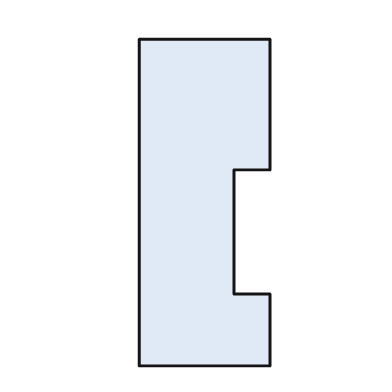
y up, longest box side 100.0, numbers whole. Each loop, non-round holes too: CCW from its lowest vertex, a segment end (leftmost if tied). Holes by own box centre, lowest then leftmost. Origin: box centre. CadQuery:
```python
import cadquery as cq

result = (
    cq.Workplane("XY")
    .moveTo(-20.0, -50.0)
    .lineTo(20.0, -50.0)
    .lineTo(20.0, -28.0)
    .lineTo(9.0, -28.0)
    .lineTo(9.0, 10.0)
    .lineTo(20.0, 10.0)
    .lineTo(20.0, 50.0)
    .lineTo(-20.0, 50.0)
    .close()
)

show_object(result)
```